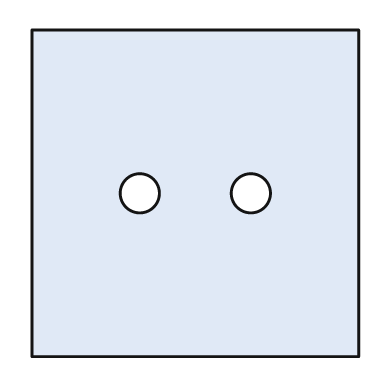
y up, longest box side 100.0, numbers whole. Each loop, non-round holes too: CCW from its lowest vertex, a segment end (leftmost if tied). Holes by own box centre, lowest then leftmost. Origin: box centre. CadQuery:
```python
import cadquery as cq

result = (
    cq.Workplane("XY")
    .moveTo(-50.0, -50.0)
    .lineTo(50.0, -50.0)
    .lineTo(50.0, 50.0)
    .lineTo(-50.0, 50.0)
    .close()
    .moveTo(-17.0, 0.0)
    .circle(6.0)
    .moveTo(17.0, 0.0)
    .circle(6.0)
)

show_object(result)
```